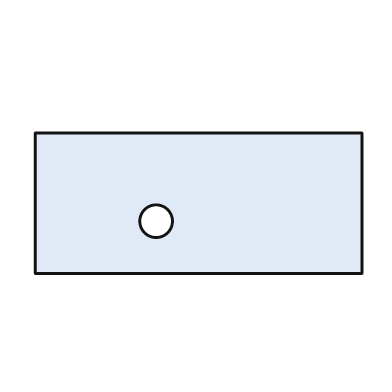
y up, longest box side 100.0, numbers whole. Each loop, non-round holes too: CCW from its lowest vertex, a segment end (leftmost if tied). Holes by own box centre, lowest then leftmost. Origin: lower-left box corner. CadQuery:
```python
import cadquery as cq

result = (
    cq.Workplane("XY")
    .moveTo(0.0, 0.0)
    .lineTo(100.0, 0.0)
    .lineTo(100.0, 43.0)
    .lineTo(0.0, 43.0)
    .close()
    .moveTo(37.0, 16.0)
    .circle(5.0)
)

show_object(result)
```